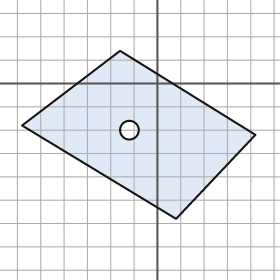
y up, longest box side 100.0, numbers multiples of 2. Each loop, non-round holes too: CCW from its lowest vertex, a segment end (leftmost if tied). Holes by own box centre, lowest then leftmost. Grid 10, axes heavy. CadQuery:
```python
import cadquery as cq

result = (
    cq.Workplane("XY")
    .moveTo(8.0, -58.0)
    .lineTo(42.0, -22.0)
    .lineTo(-16.0, 14.0)
    .lineTo(-58.0, -18.0)
    .close()
    .moveTo(-12.0, -20.0)
    .circle(4.0)
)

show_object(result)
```